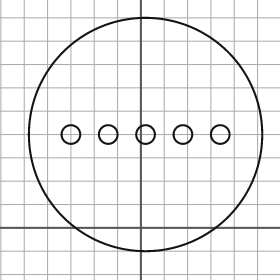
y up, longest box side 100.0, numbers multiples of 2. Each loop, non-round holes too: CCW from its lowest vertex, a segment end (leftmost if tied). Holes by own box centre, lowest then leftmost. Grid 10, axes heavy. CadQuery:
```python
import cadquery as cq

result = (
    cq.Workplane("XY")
    .moveTo(2.0, 40.0)
    .circle(50.0)
    .moveTo(-30.0, 40.0)
    .circle(4.0)
    .moveTo(-14.0, 40.0)
    .circle(4.0)
    .moveTo(2.0, 40.0)
    .circle(4.0)
    .moveTo(18.0, 40.0)
    .circle(4.0)
    .moveTo(34.0, 40.0)
    .circle(4.0)
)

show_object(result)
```